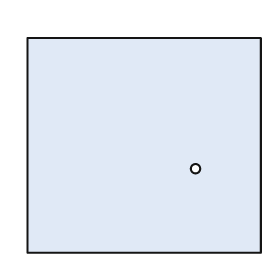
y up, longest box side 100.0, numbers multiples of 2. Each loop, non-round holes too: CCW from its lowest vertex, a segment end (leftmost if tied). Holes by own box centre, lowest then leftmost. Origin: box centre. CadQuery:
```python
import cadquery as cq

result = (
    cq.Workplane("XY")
    .moveTo(-50.0, -46.0)
    .lineTo(50.0, -46.0)
    .lineTo(50.0, 46.0)
    .lineTo(-50.0, 46.0)
    .close()
    .moveTo(22.0, -10.0)
    .circle(2.0)
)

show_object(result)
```